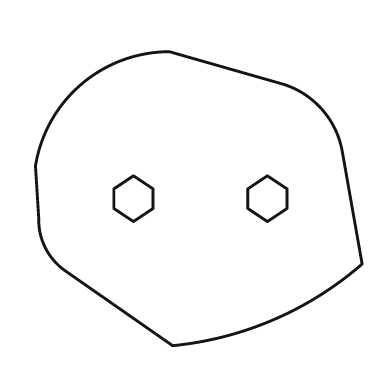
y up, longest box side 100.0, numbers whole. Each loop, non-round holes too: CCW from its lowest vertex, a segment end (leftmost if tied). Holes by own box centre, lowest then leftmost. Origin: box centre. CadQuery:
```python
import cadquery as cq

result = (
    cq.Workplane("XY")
    .moveTo(-8.0, -45.0)
    .threePointArc((23.0, -37.0), (50.0, -20.0))
    .lineTo(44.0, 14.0)
    .threePointArc((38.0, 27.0), (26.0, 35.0))
    .lineTo(-9.0, 45.0)
    .threePointArc((-36.0, 35.0), (-50.0, 10.0))
    .lineTo(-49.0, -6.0)
    .threePointArc((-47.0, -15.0), (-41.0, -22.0))
    .close()
    .moveTo(-20.0, -7.0)
    .lineTo(-14.0, -3.0)
    .lineTo(-14.0, 3.0)
    .lineTo(-20.0, 7.0)
    .lineTo(-26.0, 3.0)
    .lineTo(-26.0, -3.0)
    .close()
    .moveTo(21.0, -7.0)
    .lineTo(27.0, -3.0)
    .lineTo(27.0, 3.0)
    .lineTo(21.0, 7.0)
    .lineTo(15.0, 3.0)
    .lineTo(15.0, -3.0)
    .close()
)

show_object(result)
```